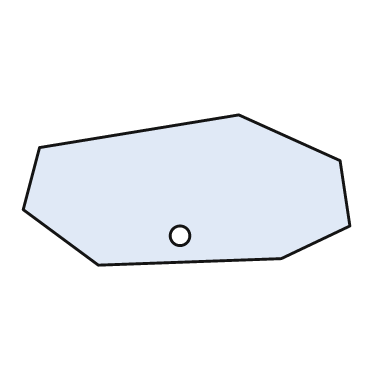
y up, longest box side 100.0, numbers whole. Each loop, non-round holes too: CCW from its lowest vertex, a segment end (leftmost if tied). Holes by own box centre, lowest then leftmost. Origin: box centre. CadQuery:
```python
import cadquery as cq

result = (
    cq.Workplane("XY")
    .moveTo(-27.0, -23.0)
    .lineTo(29.0, -21.0)
    .lineTo(50.0, -11.0)
    .lineTo(47.0, 9.0)
    .lineTo(16.0, 23.0)
    .lineTo(-45.0, 13.0)
    .lineTo(-50.0, -6.0)
    .close()
    .moveTo(-2.0, -14.0)
    .circle(3.0)
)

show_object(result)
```